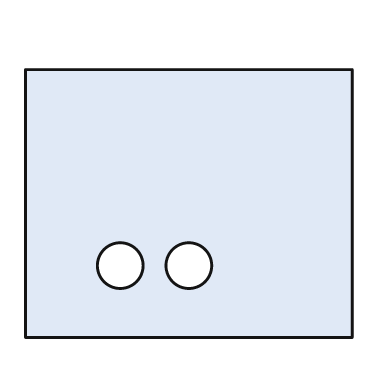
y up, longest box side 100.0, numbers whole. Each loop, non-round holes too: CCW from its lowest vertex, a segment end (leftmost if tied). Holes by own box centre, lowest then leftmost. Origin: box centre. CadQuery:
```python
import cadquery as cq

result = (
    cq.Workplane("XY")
    .moveTo(-50.0, -41.0)
    .lineTo(50.0, -41.0)
    .lineTo(50.0, 41.0)
    .lineTo(-50.0, 41.0)
    .close()
    .moveTo(-21.0, -19.0)
    .circle(7.0)
    .moveTo(0.0, -19.0)
    .circle(7.0)
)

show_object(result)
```